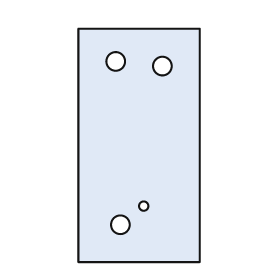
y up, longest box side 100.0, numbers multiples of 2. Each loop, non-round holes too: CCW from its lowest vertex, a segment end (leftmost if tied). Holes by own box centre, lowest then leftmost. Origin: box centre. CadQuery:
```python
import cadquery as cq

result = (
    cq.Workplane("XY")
    .moveTo(-26.0, -50.0)
    .lineTo(26.0, -50.0)
    .lineTo(26.0, 50.0)
    .lineTo(-26.0, 50.0)
    .close()
    .moveTo(-8.0, -34.0)
    .circle(4.0)
    .moveTo(2.0, -26.0)
    .circle(2.0)
    .moveTo(10.0, 34.0)
    .circle(4.0)
    .moveTo(-10.0, 36.0)
    .circle(4.0)
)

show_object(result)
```